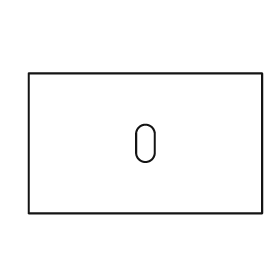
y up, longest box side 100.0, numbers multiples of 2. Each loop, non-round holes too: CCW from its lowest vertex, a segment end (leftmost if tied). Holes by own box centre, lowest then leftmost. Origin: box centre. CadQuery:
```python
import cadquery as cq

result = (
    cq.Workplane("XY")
    .moveTo(-50.0, -30.0)
    .lineTo(50.0, -30.0)
    .lineTo(50.0, 30.0)
    .lineTo(-50.0, 30.0)
    .close()
    .moveTo(-4.0, -4.0)
    .threePointArc((0.0, -8.0), (4.0, -4.0))
    .lineTo(4.0, 4.0)
    .threePointArc((0.0, 8.0), (-4.0, 4.0))
    .close()
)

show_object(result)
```